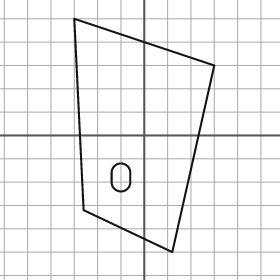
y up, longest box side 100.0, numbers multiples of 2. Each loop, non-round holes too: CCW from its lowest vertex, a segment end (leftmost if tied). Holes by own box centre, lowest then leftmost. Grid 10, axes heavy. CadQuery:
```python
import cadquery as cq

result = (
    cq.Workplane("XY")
    .moveTo(12.0, -50.0)
    .lineTo(30.0, 30.0)
    .lineTo(-30.0, 50.0)
    .lineTo(-26.0, -32.0)
    .close()
    .moveTo(-14.0, -20.0)
    .threePointArc((-10.0, -24.0), (-6.0, -20.0))
    .lineTo(-6.0, -16.0)
    .threePointArc((-10.0, -12.0), (-14.0, -16.0))
    .close()
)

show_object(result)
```